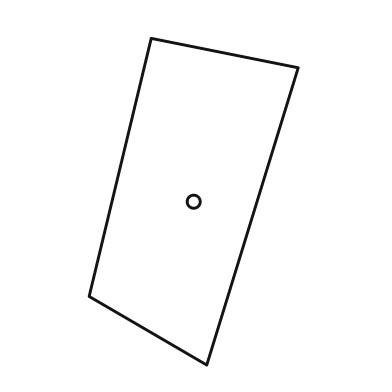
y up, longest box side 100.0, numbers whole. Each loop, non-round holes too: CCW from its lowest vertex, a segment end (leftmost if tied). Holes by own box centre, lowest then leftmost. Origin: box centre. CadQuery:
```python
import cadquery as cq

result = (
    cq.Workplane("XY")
    .moveTo(4.0, -50.0)
    .lineTo(32.0, 41.0)
    .lineTo(-13.0, 50.0)
    .lineTo(-32.0, -29.0)
    .close()
    .moveTo(0.0, 0.0)
    .circle(2.0)
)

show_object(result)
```